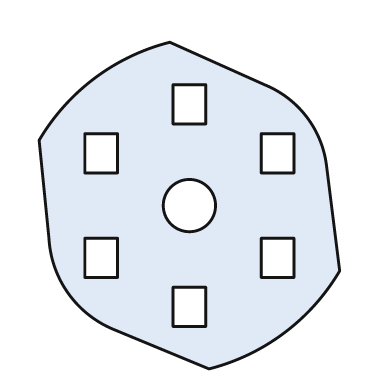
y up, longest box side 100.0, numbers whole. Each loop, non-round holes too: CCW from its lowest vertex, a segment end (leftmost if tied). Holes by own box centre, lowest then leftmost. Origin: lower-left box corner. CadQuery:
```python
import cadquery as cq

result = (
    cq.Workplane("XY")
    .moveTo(52.0, 0.0)
    .threePointArc((75.0, 11.0), (92.0, 30.0))
    .lineTo(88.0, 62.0)
    .threePointArc((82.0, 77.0), (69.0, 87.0))
    .lineTo(40.0, 100.0)
    .threePointArc((17.0, 89.0), (0.0, 70.0))
    .lineTo(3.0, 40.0)
    .threePointArc((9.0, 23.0), (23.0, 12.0))
    .close()
    .moveTo(41.0, 13.0)
    .lineTo(51.0, 13.0)
    .lineTo(51.0, 25.0)
    .lineTo(41.0, 25.0)
    .close()
    .moveTo(14.0, 28.0)
    .lineTo(24.0, 28.0)
    .lineTo(24.0, 40.0)
    .lineTo(14.0, 40.0)
    .close()
    .moveTo(68.0, 28.0)
    .lineTo(78.0, 28.0)
    .lineTo(78.0, 40.0)
    .lineTo(68.0, 40.0)
    .close()
    .moveTo(46.0, 50.0)
    .circle(8.0)
    .moveTo(14.0, 60.0)
    .lineTo(24.0, 60.0)
    .lineTo(24.0, 72.0)
    .lineTo(14.0, 72.0)
    .close()
    .moveTo(68.0, 60.0)
    .lineTo(78.0, 60.0)
    .lineTo(78.0, 72.0)
    .lineTo(68.0, 72.0)
    .close()
    .moveTo(41.0, 75.0)
    .lineTo(51.0, 75.0)
    .lineTo(51.0, 87.0)
    .lineTo(41.0, 87.0)
    .close()
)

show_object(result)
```